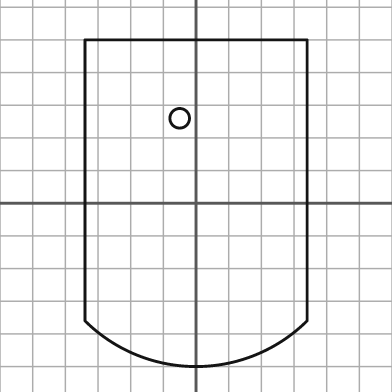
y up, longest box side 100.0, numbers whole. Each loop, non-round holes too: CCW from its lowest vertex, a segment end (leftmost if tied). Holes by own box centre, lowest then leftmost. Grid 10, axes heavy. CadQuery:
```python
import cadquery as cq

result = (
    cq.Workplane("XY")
    .moveTo(-34.0, -36.0)
    .threePointArc((0.0, -50.0), (34.0, -36.0))
    .lineTo(34.0, 50.0)
    .lineTo(-34.0, 50.0)
    .close()
    .moveTo(-5.0, 26.0)
    .circle(3.0)
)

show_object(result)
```